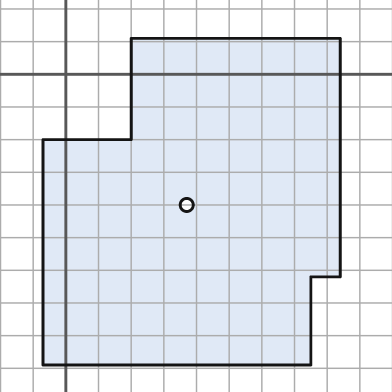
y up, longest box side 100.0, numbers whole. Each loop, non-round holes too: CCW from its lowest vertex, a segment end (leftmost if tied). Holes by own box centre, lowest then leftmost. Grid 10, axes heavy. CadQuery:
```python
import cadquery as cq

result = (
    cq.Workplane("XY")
    .moveTo(-7.0, -89.0)
    .lineTo(75.0, -89.0)
    .lineTo(75.0, -62.0)
    .lineTo(84.0, -62.0)
    .lineTo(84.0, 11.0)
    .lineTo(20.0, 11.0)
    .lineTo(20.0, -20.0)
    .lineTo(-7.0, -20.0)
    .close()
    .moveTo(37.0, -40.0)
    .circle(2.0)
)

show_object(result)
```